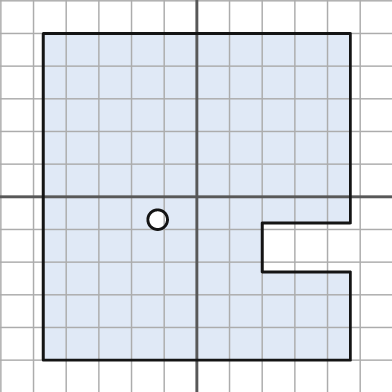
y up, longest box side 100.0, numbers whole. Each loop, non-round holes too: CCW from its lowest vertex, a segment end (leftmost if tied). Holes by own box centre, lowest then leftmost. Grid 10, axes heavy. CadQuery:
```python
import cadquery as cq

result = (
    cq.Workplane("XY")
    .moveTo(-47.0, -50.0)
    .lineTo(47.0, -50.0)
    .lineTo(47.0, -23.0)
    .lineTo(20.0, -23.0)
    .lineTo(20.0, -8.0)
    .lineTo(47.0, -8.0)
    .lineTo(47.0, 50.0)
    .lineTo(-47.0, 50.0)
    .close()
    .moveTo(-12.0, -7.0)
    .circle(3.0)
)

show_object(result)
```